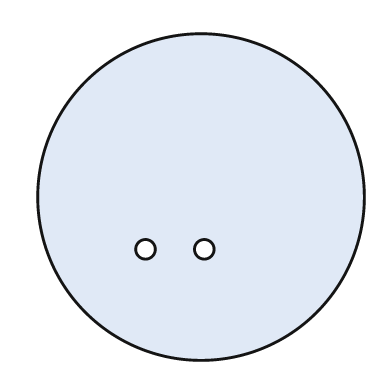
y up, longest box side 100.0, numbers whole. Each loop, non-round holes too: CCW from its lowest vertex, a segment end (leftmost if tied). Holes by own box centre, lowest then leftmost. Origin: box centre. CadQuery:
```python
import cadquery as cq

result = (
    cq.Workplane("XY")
    .moveTo(0.0, 0.0)
    .circle(50.0)
    .moveTo(-17.0, -16.0)
    .circle(3.0)
    .moveTo(1.0, -16.0)
    .circle(3.0)
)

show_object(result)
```